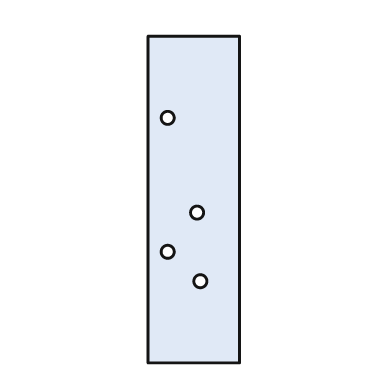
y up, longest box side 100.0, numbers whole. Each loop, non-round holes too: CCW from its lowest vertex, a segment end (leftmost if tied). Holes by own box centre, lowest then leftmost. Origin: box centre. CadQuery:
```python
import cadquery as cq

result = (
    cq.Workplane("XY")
    .moveTo(-14.0, -50.0)
    .lineTo(14.0, -50.0)
    .lineTo(14.0, 50.0)
    .lineTo(-14.0, 50.0)
    .close()
    .moveTo(2.0, -25.0)
    .circle(2.0)
    .moveTo(-8.0, -16.0)
    .circle(2.0)
    .moveTo(1.0, -4.0)
    .circle(2.0)
    .moveTo(-8.0, 25.0)
    .circle(2.0)
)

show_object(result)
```